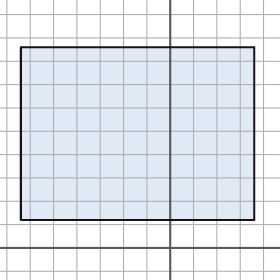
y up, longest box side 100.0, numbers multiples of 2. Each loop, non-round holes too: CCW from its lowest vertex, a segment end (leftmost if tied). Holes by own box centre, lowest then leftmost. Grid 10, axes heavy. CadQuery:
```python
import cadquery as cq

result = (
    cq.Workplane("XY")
    .moveTo(-64.0, 12.0)
    .lineTo(36.0, 12.0)
    .lineTo(36.0, 86.0)
    .lineTo(-64.0, 86.0)
    .close()
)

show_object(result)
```